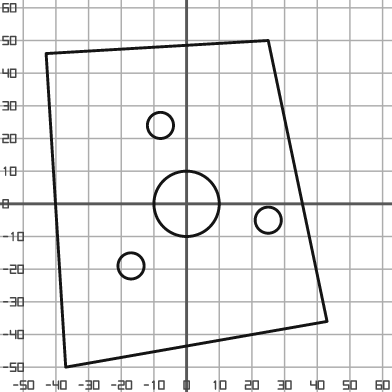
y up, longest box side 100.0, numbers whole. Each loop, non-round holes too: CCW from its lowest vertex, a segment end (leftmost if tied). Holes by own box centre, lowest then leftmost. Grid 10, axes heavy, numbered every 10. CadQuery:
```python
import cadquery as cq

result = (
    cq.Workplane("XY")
    .moveTo(-37.0, -50.0)
    .lineTo(43.0, -36.0)
    .lineTo(25.0, 50.0)
    .lineTo(-43.0, 46.0)
    .close()
    .moveTo(-17.0, -19.0)
    .circle(4.0)
    .moveTo(25.0, -5.0)
    .circle(4.0)
    .moveTo(0.0, 0.0)
    .circle(10.0)
    .moveTo(-8.0, 24.0)
    .circle(4.0)
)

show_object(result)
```